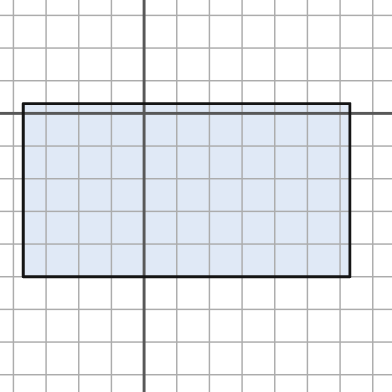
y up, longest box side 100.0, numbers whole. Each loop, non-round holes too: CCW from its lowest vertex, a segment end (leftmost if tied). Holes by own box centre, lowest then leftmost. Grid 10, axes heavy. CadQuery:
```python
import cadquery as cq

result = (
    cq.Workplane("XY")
    .moveTo(-37.0, -50.0)
    .lineTo(63.0, -50.0)
    .lineTo(63.0, 3.0)
    .lineTo(-37.0, 3.0)
    .close()
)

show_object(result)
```